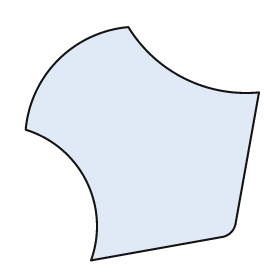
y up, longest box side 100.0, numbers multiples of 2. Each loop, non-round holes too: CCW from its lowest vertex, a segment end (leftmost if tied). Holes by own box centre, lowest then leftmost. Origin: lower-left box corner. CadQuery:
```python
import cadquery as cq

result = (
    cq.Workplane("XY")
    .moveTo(28.0, 0.0)
    .lineTo(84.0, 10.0)
    .threePointArc((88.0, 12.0), (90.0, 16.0))
    .lineTo(100.0, 72.0)
    .threePointArc((68.0, 78.0), (44.0, 100.0))
    .threePointArc((14.0, 86.0), (0.0, 56.0))
    .threePointArc((26.0, 34.0), (28.0, 0.0))
    .close()
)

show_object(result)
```